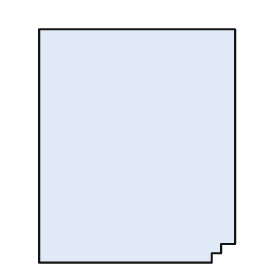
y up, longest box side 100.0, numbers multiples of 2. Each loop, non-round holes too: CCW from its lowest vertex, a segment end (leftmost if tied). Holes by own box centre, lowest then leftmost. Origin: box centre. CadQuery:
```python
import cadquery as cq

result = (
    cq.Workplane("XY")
    .moveTo(-42.0, -50.0)
    .lineTo(32.0, -50.0)
    .lineTo(32.0, -46.0)
    .lineTo(36.0, -46.0)
    .lineTo(36.0, -42.0)
    .lineTo(42.0, -42.0)
    .lineTo(42.0, 50.0)
    .lineTo(-42.0, 50.0)
    .close()
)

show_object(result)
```